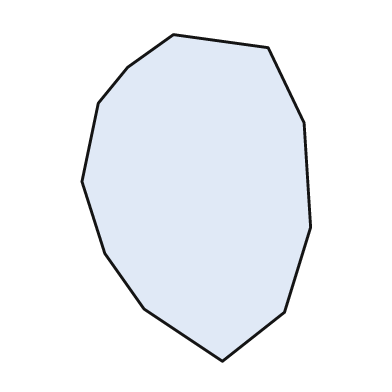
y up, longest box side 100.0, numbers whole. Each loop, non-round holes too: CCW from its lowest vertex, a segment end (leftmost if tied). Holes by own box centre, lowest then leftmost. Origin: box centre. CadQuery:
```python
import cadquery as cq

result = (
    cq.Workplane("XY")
    .moveTo(8.0, -50.0)
    .lineTo(27.0, -35.0)
    .lineTo(35.0, -9.0)
    .lineTo(33.0, 23.0)
    .lineTo(22.0, 46.0)
    .lineTo(-7.0, 50.0)
    .lineTo(-21.0, 40.0)
    .lineTo(-30.0, 29.0)
    .lineTo(-35.0, 5.0)
    .lineTo(-28.0, -17.0)
    .lineTo(-16.0, -34.0)
    .close()
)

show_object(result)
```